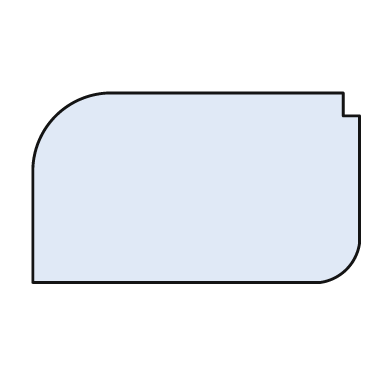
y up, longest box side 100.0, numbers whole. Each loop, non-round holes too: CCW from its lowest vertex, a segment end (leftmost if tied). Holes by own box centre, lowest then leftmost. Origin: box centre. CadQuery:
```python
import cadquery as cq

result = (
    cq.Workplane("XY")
    .moveTo(-50.0, -29.0)
    .lineTo(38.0, -29.0)
    .threePointArc((46.0, -25.0), (50.0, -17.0))
    .lineTo(50.0, 22.0)
    .lineTo(45.0, 22.0)
    .lineTo(45.0, 29.0)
    .lineTo(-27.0, 29.0)
    .threePointArc((-43.0, 22.0), (-50.0, 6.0))
    .close()
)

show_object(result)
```